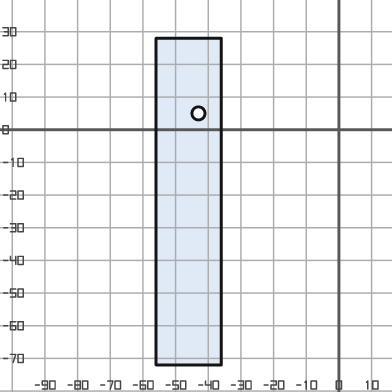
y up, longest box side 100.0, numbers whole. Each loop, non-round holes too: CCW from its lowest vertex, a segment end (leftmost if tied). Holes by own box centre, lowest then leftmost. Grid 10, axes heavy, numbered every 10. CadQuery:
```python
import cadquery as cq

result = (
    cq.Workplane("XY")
    .moveTo(-56.0, -72.0)
    .lineTo(-36.0, -72.0)
    .lineTo(-36.0, 28.0)
    .lineTo(-56.0, 28.0)
    .close()
    .moveTo(-43.0, 5.0)
    .circle(2.0)
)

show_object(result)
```